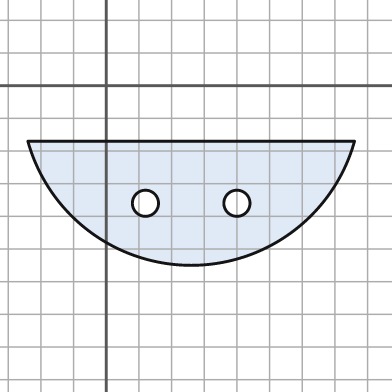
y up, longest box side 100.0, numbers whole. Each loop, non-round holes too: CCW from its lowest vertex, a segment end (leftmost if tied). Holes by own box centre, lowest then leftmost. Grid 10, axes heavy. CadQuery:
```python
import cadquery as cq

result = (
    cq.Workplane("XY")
    .moveTo(-24.0, -17.0)
    .threePointArc((26.0, -55.0), (76.0, -17.0))
    .close()
    .moveTo(12.0, -36.0)
    .circle(4.0)
    .moveTo(40.0, -36.0)
    .circle(4.0)
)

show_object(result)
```